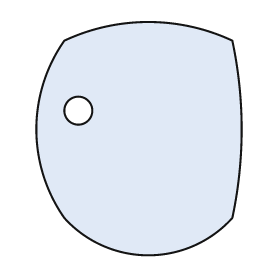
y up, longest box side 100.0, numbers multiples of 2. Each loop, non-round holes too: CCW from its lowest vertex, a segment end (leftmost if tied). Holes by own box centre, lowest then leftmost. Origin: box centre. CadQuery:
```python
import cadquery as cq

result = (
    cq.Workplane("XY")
    .moveTo(-32.0, -34.0)
    .threePointArc((4.0, -50.0), (40.0, -34.0))
    .threePointArc((44.0, 4.0), (40.0, 42.0))
    .threePointArc((4.0, 50.0), (-32.0, 42.0))
    .threePointArc((-44.0, 4.0), (-32.0, -34.0))
    .close()
    .moveTo(-26.0, 12.0)
    .circle(6.0)
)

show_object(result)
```